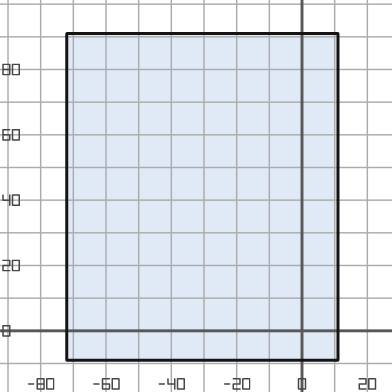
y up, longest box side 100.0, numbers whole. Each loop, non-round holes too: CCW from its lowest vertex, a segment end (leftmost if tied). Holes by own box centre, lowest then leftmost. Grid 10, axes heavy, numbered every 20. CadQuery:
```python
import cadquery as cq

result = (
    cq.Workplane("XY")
    .moveTo(-72.0, -9.0)
    .lineTo(11.0, -9.0)
    .lineTo(11.0, 91.0)
    .lineTo(-72.0, 91.0)
    .close()
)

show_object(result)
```